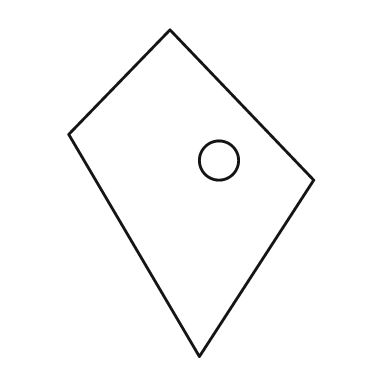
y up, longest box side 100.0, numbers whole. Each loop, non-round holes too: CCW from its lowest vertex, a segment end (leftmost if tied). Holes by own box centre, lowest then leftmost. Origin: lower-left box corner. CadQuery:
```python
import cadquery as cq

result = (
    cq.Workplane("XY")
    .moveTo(40.0, 0.0)
    .lineTo(75.0, 54.0)
    .lineTo(31.0, 100.0)
    .lineTo(0.0, 68.0)
    .close()
    .moveTo(46.0, 60.0)
    .circle(6.0)
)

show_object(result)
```